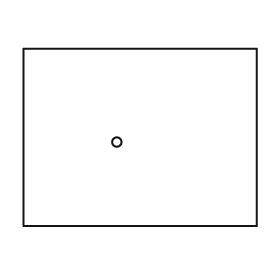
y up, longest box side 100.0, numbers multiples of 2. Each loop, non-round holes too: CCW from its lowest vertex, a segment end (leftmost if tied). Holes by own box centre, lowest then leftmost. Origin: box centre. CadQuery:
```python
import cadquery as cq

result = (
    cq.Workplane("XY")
    .moveTo(-50.0, -38.0)
    .lineTo(50.0, -38.0)
    .lineTo(50.0, 38.0)
    .lineTo(-50.0, 38.0)
    .close()
    .moveTo(-10.0, -2.0)
    .circle(2.0)
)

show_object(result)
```